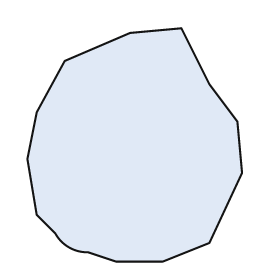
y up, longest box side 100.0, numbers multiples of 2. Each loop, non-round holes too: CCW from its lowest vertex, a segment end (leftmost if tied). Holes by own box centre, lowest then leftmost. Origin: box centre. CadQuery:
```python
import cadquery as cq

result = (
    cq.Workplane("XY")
    .moveTo(-8.0, -50.0)
    .lineTo(12.0, -50.0)
    .lineTo(32.0, -42.0)
    .lineTo(46.0, -12.0)
    .lineTo(44.0, 10.0)
    .lineTo(32.0, 26.0)
    .lineTo(20.0, 50.0)
    .lineTo(-2.0, 48.0)
    .lineTo(-30.0, 36.0)
    .lineTo(-42.0, 14.0)
    .lineTo(-46.0, -6.0)
    .lineTo(-42.0, -30.0)
    .lineTo(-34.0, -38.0)
    .threePointArc((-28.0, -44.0), (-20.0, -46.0))
    .close()
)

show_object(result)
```